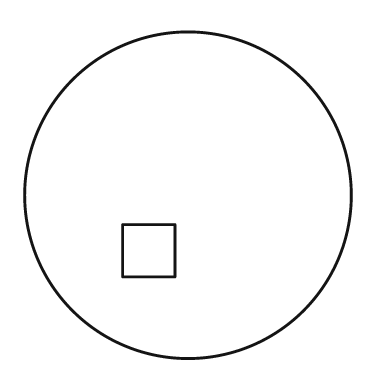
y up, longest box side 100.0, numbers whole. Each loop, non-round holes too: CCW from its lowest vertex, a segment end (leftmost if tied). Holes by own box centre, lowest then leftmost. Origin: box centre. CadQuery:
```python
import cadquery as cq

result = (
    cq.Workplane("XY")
    .moveTo(0.0, 0.0)
    .circle(50.0)
    .moveTo(-20.0, -25.0)
    .lineTo(-4.0, -25.0)
    .lineTo(-4.0, -9.0)
    .lineTo(-20.0, -9.0)
    .close()
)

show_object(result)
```